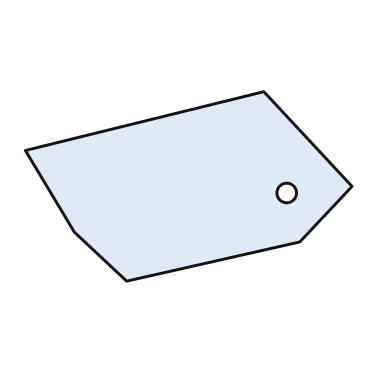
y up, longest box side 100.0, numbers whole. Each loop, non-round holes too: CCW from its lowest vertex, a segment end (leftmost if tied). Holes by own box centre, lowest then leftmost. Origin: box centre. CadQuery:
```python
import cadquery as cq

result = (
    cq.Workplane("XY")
    .moveTo(-19.0, -29.0)
    .lineTo(34.0, -17.0)
    .lineTo(50.0, 0.0)
    .lineTo(23.0, 29.0)
    .lineTo(-50.0, 11.0)
    .lineTo(-35.0, -14.0)
    .close()
    .moveTo(30.0, -2.0)
    .circle(3.0)
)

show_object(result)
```